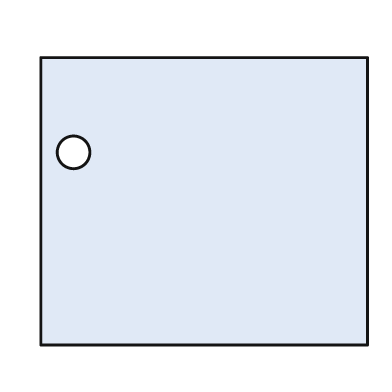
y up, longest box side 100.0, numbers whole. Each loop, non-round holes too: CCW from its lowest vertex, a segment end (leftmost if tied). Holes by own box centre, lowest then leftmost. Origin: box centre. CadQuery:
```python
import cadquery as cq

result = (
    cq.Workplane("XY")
    .moveTo(-50.0, -44.0)
    .lineTo(50.0, -44.0)
    .lineTo(50.0, 44.0)
    .lineTo(-50.0, 44.0)
    .close()
    .moveTo(-40.0, 15.0)
    .circle(5.0)
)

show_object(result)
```